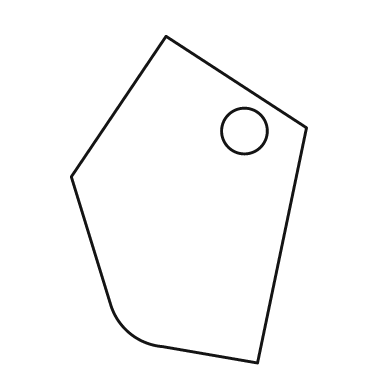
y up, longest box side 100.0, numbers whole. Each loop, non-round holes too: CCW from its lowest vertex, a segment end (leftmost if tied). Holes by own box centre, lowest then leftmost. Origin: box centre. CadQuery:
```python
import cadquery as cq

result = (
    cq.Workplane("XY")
    .moveTo(21.0, -50.0)
    .lineTo(36.0, 22.0)
    .lineTo(-7.0, 50.0)
    .lineTo(-36.0, 7.0)
    .lineTo(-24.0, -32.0)
    .threePointArc((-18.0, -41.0), (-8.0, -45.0))
    .close()
    .moveTo(17.0, 21.0)
    .circle(7.0)
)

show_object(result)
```